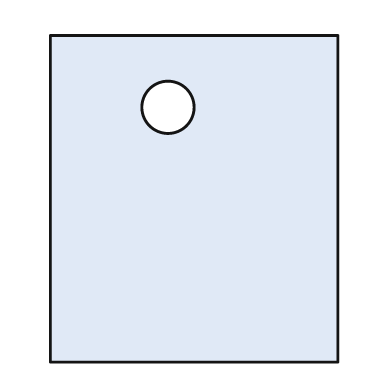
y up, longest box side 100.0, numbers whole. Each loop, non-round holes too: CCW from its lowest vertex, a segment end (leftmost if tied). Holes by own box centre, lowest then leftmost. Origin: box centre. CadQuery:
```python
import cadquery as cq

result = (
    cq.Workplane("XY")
    .moveTo(-44.0, -50.0)
    .lineTo(44.0, -50.0)
    .lineTo(44.0, 50.0)
    .lineTo(-44.0, 50.0)
    .close()
    .moveTo(-8.0, 28.0)
    .circle(8.0)
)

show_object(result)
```